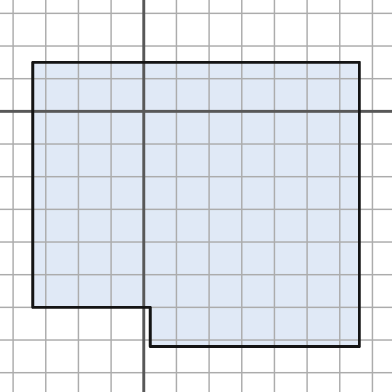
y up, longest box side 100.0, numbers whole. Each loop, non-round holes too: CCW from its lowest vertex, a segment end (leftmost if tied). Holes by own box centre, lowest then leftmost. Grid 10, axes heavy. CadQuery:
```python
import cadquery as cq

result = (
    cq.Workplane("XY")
    .moveTo(2.0, -72.0)
    .lineTo(66.0, -72.0)
    .lineTo(66.0, 15.0)
    .lineTo(-34.0, 15.0)
    .lineTo(-34.0, -60.0)
    .lineTo(2.0, -60.0)
    .close()
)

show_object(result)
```